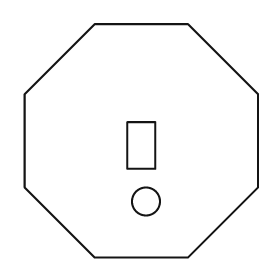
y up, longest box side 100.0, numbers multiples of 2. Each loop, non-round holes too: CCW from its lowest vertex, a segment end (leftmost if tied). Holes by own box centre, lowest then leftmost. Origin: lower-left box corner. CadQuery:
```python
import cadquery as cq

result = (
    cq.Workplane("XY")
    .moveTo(30.0, 0.0)
    .lineTo(70.0, 0.0)
    .lineTo(100.0, 30.0)
    .lineTo(100.0, 70.0)
    .lineTo(70.0, 100.0)
    .lineTo(30.0, 100.0)
    .lineTo(0.0, 70.0)
    .lineTo(0.0, 30.0)
    .close()
    .moveTo(52.0, 24.0)
    .circle(6.0)
    .moveTo(44.0, 38.0)
    .lineTo(56.0, 38.0)
    .lineTo(56.0, 58.0)
    .lineTo(44.0, 58.0)
    .close()
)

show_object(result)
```